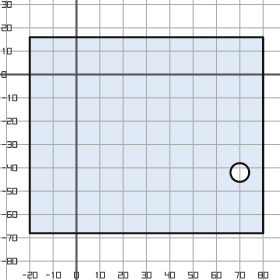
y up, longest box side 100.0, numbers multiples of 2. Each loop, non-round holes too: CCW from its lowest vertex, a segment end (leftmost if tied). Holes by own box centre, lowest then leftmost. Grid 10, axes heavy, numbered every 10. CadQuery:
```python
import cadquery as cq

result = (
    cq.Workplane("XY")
    .moveTo(-20.0, -68.0)
    .lineTo(80.0, -68.0)
    .lineTo(80.0, 16.0)
    .lineTo(-20.0, 16.0)
    .close()
    .moveTo(70.0, -42.0)
    .circle(4.0)
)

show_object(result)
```